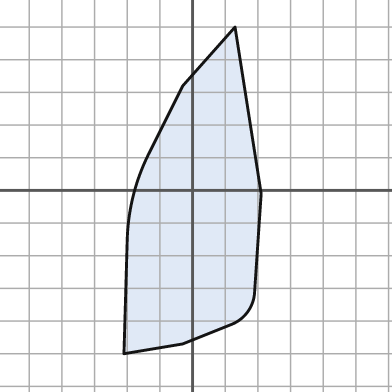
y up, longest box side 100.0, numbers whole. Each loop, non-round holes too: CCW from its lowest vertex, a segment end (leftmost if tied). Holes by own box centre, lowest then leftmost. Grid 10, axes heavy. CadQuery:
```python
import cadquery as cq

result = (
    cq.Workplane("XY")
    .moveTo(-21.0, -50.0)
    .lineTo(-3.0, -47.0)
    .lineTo(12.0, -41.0)
    .threePointArc((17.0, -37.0), (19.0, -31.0))
    .lineTo(21.0, -1.0)
    .lineTo(13.0, 50.0)
    .lineTo(-3.0, 32.0)
    .lineTo(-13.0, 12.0)
    .threePointArc((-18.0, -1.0), (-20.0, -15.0))
    .close()
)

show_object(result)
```